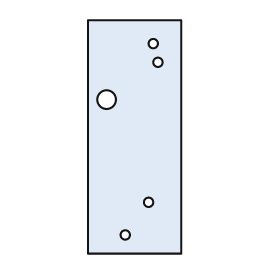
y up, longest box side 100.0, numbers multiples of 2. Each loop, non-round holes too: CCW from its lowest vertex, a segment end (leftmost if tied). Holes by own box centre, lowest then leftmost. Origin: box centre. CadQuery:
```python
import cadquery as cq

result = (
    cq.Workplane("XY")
    .moveTo(-20.0, -50.0)
    .lineTo(20.0, -50.0)
    .lineTo(20.0, 50.0)
    .lineTo(-20.0, 50.0)
    .close()
    .moveTo(-4.0, -42.0)
    .circle(2.0)
    .moveTo(6.0, -28.0)
    .circle(2.0)
    .moveTo(-12.0, 16.0)
    .circle(4.0)
    .moveTo(10.0, 32.0)
    .circle(2.0)
    .moveTo(8.0, 40.0)
    .circle(2.0)
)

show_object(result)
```